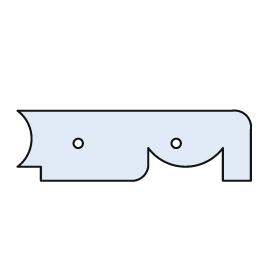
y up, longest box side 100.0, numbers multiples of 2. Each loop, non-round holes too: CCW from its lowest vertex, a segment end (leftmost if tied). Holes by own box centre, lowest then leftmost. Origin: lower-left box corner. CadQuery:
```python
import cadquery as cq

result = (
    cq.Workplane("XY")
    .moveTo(10.0, 0.0)
    .lineTo(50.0, 0.0)
    .threePointArc((54.0, 2.0), (56.0, 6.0))
    .lineTo(56.0, 14.0)
    .threePointArc((72.0, 6.0), (88.0, 14.0))
    .lineTo(88.0, 0.0)
    .lineTo(100.0, 0.0)
    .lineTo(100.0, 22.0)
    .threePointArc((98.0, 28.0), (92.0, 30.0))
    .lineTo(0.0, 30.0)
    .threePointArc((6.0, 18.0), (0.0, 6.0))
    .lineTo(10.0, 6.0)
    .close()
    .moveTo(26.0, 16.0)
    .circle(2.0)
    .moveTo(68.0, 16.0)
    .circle(2.0)
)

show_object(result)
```